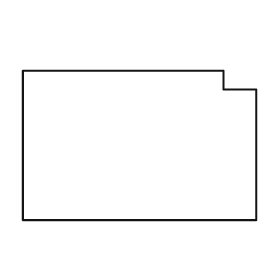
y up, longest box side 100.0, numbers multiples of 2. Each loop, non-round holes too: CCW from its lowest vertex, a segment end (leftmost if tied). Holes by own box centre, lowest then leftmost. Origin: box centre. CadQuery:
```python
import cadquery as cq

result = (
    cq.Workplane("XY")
    .moveTo(-50.0, -32.0)
    .lineTo(50.0, -32.0)
    .lineTo(50.0, 24.0)
    .lineTo(36.0, 24.0)
    .lineTo(36.0, 32.0)
    .lineTo(-50.0, 32.0)
    .close()
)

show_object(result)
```